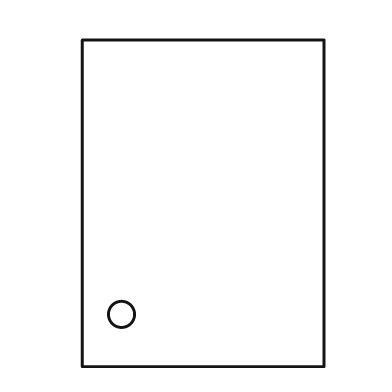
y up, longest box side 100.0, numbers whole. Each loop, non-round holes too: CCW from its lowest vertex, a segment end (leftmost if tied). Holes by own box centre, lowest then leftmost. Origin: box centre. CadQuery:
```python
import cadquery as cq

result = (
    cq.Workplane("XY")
    .moveTo(-37.0, -50.0)
    .lineTo(37.0, -50.0)
    .lineTo(37.0, 50.0)
    .lineTo(-37.0, 50.0)
    .close()
    .moveTo(-25.0, -34.0)
    .circle(4.0)
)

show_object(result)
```